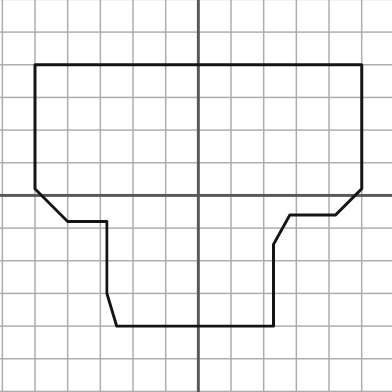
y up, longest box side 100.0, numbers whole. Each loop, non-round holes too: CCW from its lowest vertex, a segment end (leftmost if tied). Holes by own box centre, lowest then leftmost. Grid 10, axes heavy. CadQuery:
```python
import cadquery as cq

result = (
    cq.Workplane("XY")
    .moveTo(-25.0, -40.0)
    .lineTo(23.0, -40.0)
    .lineTo(23.0, -15.0)
    .lineTo(28.0, -6.0)
    .lineTo(42.0, -6.0)
    .lineTo(50.0, 2.0)
    .lineTo(50.0, 40.0)
    .lineTo(-50.0, 40.0)
    .lineTo(-50.0, 2.0)
    .lineTo(-40.0, -8.0)
    .lineTo(-28.0, -8.0)
    .lineTo(-28.0, -30.0)
    .close()
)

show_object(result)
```